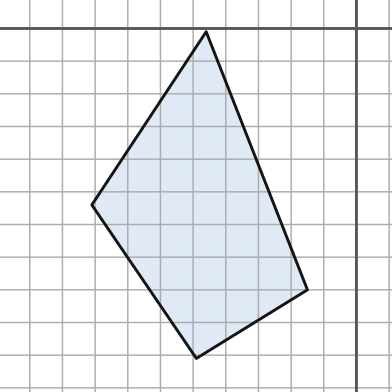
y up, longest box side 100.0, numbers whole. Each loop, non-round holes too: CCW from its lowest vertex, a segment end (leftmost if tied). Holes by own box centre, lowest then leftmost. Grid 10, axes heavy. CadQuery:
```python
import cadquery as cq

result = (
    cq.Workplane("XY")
    .moveTo(-49.0, -101.0)
    .lineTo(-15.0, -80.0)
    .lineTo(-46.0, -1.0)
    .lineTo(-81.0, -54.0)
    .close()
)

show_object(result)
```